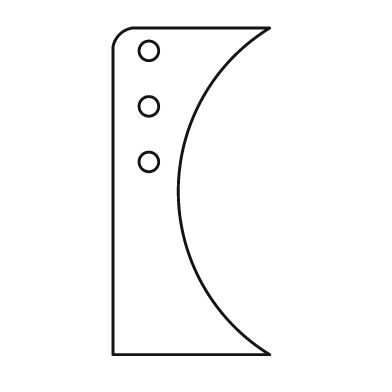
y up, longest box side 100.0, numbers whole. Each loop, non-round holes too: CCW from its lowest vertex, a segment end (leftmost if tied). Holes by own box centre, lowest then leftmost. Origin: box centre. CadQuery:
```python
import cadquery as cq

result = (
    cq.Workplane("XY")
    .moveTo(-24.0, -50.0)
    .lineTo(24.0, -50.0)
    .threePointArc((-4.0, 0.0), (24.0, 50.0))
    .lineTo(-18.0, 50.0)
    .threePointArc((-22.0, 48.0), (-24.0, 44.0))
    .close()
    .moveTo(-13.0, 9.0)
    .circle(3.0)
    .moveTo(-13.0, 26.0)
    .circle(3.0)
    .moveTo(-13.0, 43.0)
    .circle(3.0)
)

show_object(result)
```